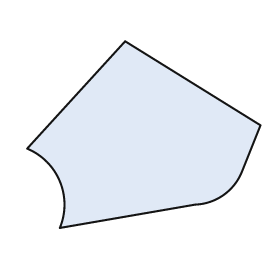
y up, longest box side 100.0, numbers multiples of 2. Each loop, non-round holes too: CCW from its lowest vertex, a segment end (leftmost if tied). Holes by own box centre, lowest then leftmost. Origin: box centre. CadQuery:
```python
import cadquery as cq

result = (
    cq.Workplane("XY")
    .moveTo(-36.0, -40.0)
    .lineTo(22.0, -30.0)
    .threePointArc((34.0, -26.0), (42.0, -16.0))
    .lineTo(50.0, 4.0)
    .lineTo(-8.0, 40.0)
    .lineTo(-50.0, -6.0)
    .threePointArc((-36.0, -20.0), (-36.0, -40.0))
    .close()
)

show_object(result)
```